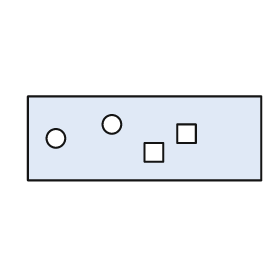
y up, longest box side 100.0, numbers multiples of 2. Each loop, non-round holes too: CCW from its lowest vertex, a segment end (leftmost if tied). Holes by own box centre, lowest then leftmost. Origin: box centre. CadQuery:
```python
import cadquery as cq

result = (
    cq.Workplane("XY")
    .moveTo(-50.0, -18.0)
    .lineTo(50.0, -18.0)
    .lineTo(50.0, 18.0)
    .lineTo(-50.0, 18.0)
    .close()
    .moveTo(0.0, -10.0)
    .lineTo(8.0, -10.0)
    .lineTo(8.0, -2.0)
    .lineTo(0.0, -2.0)
    .close()
    .moveTo(-38.0, 0.0)
    .circle(4.0)
    .moveTo(14.0, -2.0)
    .lineTo(22.0, -2.0)
    .lineTo(22.0, 6.0)
    .lineTo(14.0, 6.0)
    .close()
    .moveTo(-14.0, 6.0)
    .circle(4.0)
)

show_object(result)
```